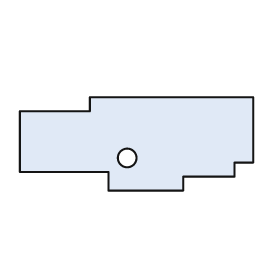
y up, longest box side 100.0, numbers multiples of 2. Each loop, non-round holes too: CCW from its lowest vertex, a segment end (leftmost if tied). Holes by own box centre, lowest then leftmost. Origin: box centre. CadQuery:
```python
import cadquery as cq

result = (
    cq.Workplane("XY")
    .moveTo(-12.0, -20.0)
    .lineTo(20.0, -20.0)
    .lineTo(20.0, -14.0)
    .lineTo(42.0, -14.0)
    .lineTo(42.0, -8.0)
    .lineTo(50.0, -8.0)
    .lineTo(50.0, 20.0)
    .lineTo(-20.0, 20.0)
    .lineTo(-20.0, 14.0)
    .lineTo(-50.0, 14.0)
    .lineTo(-50.0, -12.0)
    .lineTo(-12.0, -12.0)
    .close()
    .moveTo(-4.0, -6.0)
    .circle(4.0)
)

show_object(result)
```